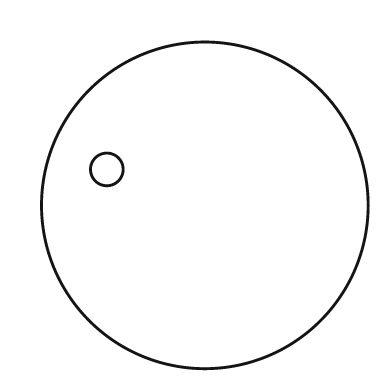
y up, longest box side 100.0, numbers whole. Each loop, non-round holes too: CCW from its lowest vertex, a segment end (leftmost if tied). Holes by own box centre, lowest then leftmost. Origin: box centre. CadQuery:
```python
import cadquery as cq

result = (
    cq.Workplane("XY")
    .moveTo(0.0, 0.0)
    .circle(50.0)
    .moveTo(-30.0, 11.0)
    .circle(5.0)
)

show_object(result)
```